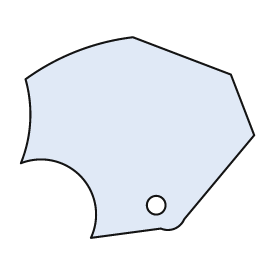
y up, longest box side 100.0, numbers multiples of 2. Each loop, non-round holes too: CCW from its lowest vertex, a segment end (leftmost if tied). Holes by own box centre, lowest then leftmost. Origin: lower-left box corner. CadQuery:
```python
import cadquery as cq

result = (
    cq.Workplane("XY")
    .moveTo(30.0, 0.0)
    .lineTo(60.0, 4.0)
    .threePointArc((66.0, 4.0), (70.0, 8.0))
    .lineTo(100.0, 44.0)
    .lineTo(90.0, 70.0)
    .lineTo(48.0, 86.0)
    .threePointArc((24.0, 80.0), (2.0, 68.0))
    .threePointArc((4.0, 50.0), (0.0, 32.0))
    .threePointArc((26.0, 26.0), (30.0, 0.0))
    .close()
    .moveTo(58.0, 14.0)
    .circle(4.0)
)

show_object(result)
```